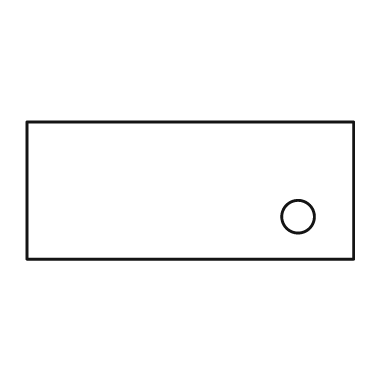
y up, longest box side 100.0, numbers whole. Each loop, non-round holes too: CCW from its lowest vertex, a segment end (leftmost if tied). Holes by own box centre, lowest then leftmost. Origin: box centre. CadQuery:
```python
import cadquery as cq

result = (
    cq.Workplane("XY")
    .moveTo(-50.0, -21.0)
    .lineTo(50.0, -21.0)
    .lineTo(50.0, 21.0)
    .lineTo(-50.0, 21.0)
    .close()
    .moveTo(33.0, -8.0)
    .circle(5.0)
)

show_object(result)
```